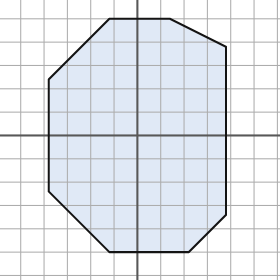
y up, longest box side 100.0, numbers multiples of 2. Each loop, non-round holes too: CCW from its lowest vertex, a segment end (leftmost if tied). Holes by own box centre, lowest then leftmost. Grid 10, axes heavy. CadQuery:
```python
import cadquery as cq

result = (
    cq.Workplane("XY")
    .moveTo(-12.0, -50.0)
    .lineTo(22.0, -50.0)
    .lineTo(38.0, -34.0)
    .lineTo(38.0, 38.0)
    .lineTo(14.0, 50.0)
    .lineTo(-12.0, 50.0)
    .lineTo(-38.0, 24.0)
    .lineTo(-38.0, -24.0)
    .close()
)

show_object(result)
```